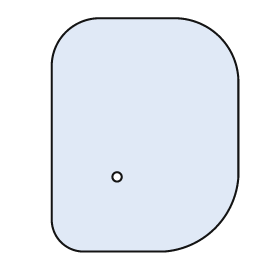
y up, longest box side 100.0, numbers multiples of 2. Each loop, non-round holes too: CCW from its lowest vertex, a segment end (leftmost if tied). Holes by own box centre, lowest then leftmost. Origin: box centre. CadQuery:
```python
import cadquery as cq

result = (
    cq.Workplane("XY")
    .moveTo(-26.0, -50.0)
    .lineTo(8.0, -50.0)
    .threePointArc((30.0, -40.0), (40.0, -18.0))
    .lineTo(40.0, 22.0)
    .threePointArc((32.0, 42.0), (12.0, 50.0))
    .lineTo(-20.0, 50.0)
    .threePointArc((-34.0, 44.0), (-40.0, 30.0))
    .lineTo(-40.0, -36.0)
    .threePointArc((-36.0, -46.0), (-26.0, -50.0))
    .close()
    .moveTo(-12.0, -18.0)
    .circle(2.0)
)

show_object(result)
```